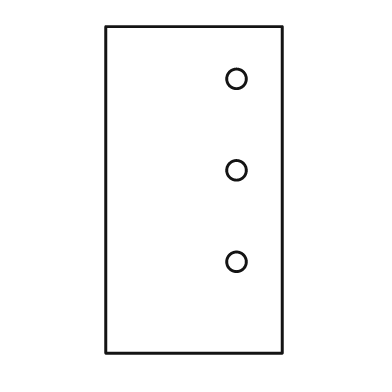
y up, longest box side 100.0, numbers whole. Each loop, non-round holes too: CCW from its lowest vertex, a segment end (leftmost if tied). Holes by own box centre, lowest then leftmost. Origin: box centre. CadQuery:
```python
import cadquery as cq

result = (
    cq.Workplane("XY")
    .moveTo(-27.0, -50.0)
    .lineTo(27.0, -50.0)
    .lineTo(27.0, 50.0)
    .lineTo(-27.0, 50.0)
    .close()
    .moveTo(13.0, -22.0)
    .circle(3.0)
    .moveTo(13.0, 6.0)
    .circle(3.0)
    .moveTo(13.0, 34.0)
    .circle(3.0)
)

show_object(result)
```